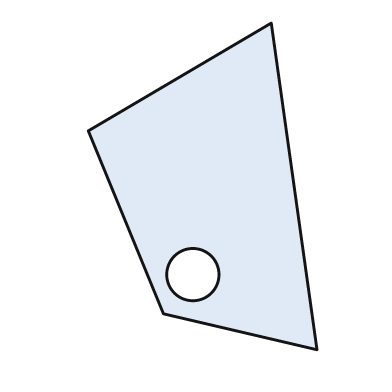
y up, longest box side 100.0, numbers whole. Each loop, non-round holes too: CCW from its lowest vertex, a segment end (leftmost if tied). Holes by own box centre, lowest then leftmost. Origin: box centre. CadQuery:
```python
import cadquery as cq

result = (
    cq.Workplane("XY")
    .moveTo(35.0, -50.0)
    .lineTo(21.0, 50.0)
    .lineTo(-35.0, 17.0)
    .lineTo(-12.0, -39.0)
    .close()
    .moveTo(-3.0, -27.0)
    .circle(8.0)
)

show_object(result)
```